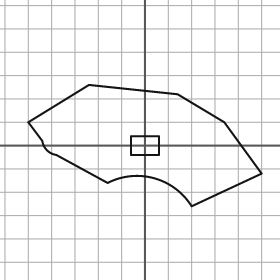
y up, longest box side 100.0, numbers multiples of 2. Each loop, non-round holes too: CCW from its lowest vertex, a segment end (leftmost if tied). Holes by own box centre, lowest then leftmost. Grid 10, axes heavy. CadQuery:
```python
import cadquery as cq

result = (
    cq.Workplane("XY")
    .moveTo(20.0, -26.0)
    .lineTo(50.0, -12.0)
    .lineTo(34.0, 10.0)
    .lineTo(14.0, 22.0)
    .lineTo(-24.0, 26.0)
    .lineTo(-50.0, 10.0)
    .lineTo(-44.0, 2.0)
    .threePointArc((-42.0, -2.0), (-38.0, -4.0))
    .lineTo(-16.0, -16.0)
    .threePointArc((4.0, -14.0), (20.0, -26.0))
    .close()
    .moveTo(-6.0, -4.0)
    .lineTo(6.0, -4.0)
    .lineTo(6.0, 4.0)
    .lineTo(-6.0, 4.0)
    .close()
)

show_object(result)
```